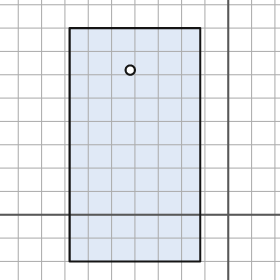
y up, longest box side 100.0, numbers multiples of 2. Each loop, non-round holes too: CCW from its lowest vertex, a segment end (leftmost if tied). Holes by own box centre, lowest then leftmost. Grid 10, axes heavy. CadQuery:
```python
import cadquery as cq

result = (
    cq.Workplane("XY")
    .moveTo(-68.0, -20.0)
    .lineTo(-12.0, -20.0)
    .lineTo(-12.0, 80.0)
    .lineTo(-68.0, 80.0)
    .close()
    .moveTo(-42.0, 62.0)
    .circle(2.0)
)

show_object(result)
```